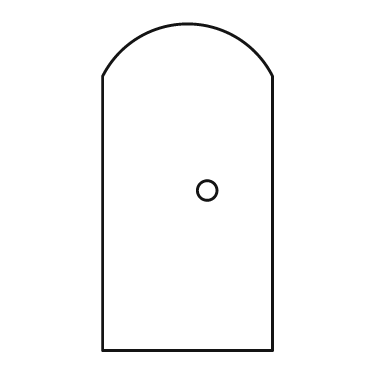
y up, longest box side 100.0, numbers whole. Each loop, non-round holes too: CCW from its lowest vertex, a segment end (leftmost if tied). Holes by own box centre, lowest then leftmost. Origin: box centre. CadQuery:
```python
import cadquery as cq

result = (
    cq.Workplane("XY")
    .moveTo(-26.0, -50.0)
    .lineTo(26.0, -50.0)
    .lineTo(26.0, 34.0)
    .threePointArc((0.0, 50.0), (-26.0, 34.0))
    .close()
    .moveTo(6.0, -1.0)
    .circle(3.0)
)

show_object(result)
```